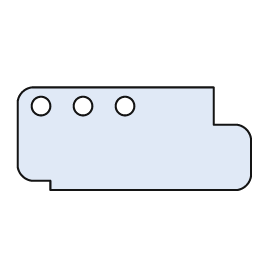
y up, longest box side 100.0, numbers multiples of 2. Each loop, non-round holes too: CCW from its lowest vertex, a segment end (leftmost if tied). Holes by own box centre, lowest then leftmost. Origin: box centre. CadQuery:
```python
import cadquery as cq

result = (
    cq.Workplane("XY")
    .moveTo(-36.0, -22.0)
    .lineTo(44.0, -22.0)
    .threePointArc((48.0, -20.0), (50.0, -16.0))
    .lineTo(50.0, 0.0)
    .threePointArc((48.0, 4.0), (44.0, 6.0))
    .lineTo(34.0, 6.0)
    .lineTo(34.0, 22.0)
    .lineTo(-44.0, 22.0)
    .threePointArc((-48.0, 20.0), (-50.0, 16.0))
    .lineTo(-50.0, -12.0)
    .threePointArc((-48.0, -16.0), (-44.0, -18.0))
    .lineTo(-36.0, -18.0)
    .close()
    .moveTo(-40.0, 14.0)
    .circle(4.0)
    .moveTo(-22.0, 14.0)
    .circle(4.0)
    .moveTo(-4.0, 14.0)
    .circle(4.0)
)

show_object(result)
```